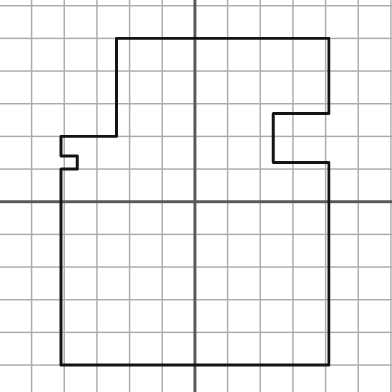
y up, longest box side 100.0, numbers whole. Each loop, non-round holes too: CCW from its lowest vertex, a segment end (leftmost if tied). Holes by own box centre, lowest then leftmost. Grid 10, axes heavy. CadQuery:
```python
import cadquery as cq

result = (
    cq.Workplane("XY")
    .moveTo(-41.0, -50.0)
    .lineTo(41.0, -50.0)
    .lineTo(41.0, 12.0)
    .lineTo(24.0, 12.0)
    .lineTo(24.0, 27.0)
    .lineTo(41.0, 27.0)
    .lineTo(41.0, 50.0)
    .lineTo(-24.0, 50.0)
    .lineTo(-24.0, 20.0)
    .lineTo(-41.0, 20.0)
    .lineTo(-41.0, 14.0)
    .lineTo(-36.0, 14.0)
    .lineTo(-36.0, 10.0)
    .lineTo(-41.0, 10.0)
    .close()
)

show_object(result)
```